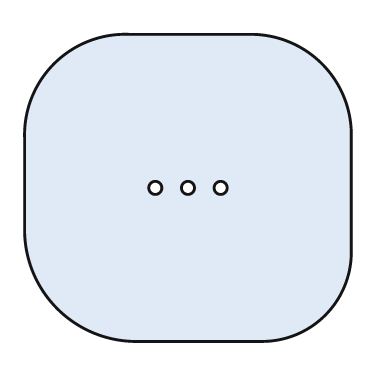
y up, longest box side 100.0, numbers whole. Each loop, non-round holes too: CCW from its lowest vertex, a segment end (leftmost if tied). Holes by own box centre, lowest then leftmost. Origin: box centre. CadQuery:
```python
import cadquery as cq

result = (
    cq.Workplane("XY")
    .moveTo(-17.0, -47.0)
    .lineTo(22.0, -47.0)
    .threePointArc((42.0, -39.0), (50.0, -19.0))
    .lineTo(50.0, 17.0)
    .threePointArc((41.0, 38.0), (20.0, 47.0))
    .lineTo(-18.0, 47.0)
    .threePointArc((-41.0, 38.0), (-50.0, 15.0))
    .lineTo(-50.0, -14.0)
    .threePointArc((-40.0, -37.0), (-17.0, -47.0))
    .close()
    .moveTo(-10.0, 0.0)
    .circle(2.0)
    .moveTo(0.0, 0.0)
    .circle(2.0)
    .moveTo(10.0, 0.0)
    .circle(2.0)
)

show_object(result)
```